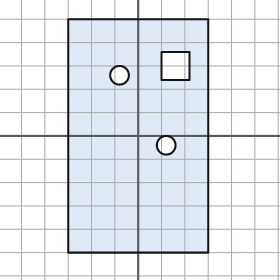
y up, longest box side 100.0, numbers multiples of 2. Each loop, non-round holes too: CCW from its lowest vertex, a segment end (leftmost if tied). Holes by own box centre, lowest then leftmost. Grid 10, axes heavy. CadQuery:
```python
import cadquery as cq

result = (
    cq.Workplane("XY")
    .moveTo(-30.0, -50.0)
    .lineTo(30.0, -50.0)
    .lineTo(30.0, 50.0)
    .lineTo(-30.0, 50.0)
    .close()
    .moveTo(12.0, -4.0)
    .circle(4.0)
    .moveTo(-8.0, 26.0)
    .circle(4.0)
    .moveTo(10.0, 24.0)
    .lineTo(22.0, 24.0)
    .lineTo(22.0, 36.0)
    .lineTo(10.0, 36.0)
    .close()
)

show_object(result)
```